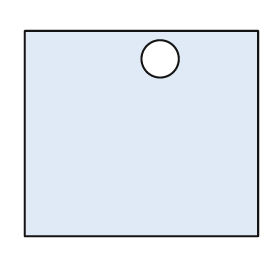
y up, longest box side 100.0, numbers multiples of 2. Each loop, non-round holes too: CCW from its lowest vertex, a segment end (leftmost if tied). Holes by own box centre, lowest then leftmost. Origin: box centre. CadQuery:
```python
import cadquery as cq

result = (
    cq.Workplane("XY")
    .moveTo(-50.0, -44.0)
    .lineTo(50.0, -44.0)
    .lineTo(50.0, 44.0)
    .lineTo(-50.0, 44.0)
    .close()
    .moveTo(8.0, 32.0)
    .circle(8.0)
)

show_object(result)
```